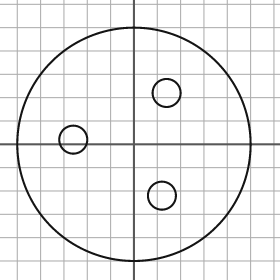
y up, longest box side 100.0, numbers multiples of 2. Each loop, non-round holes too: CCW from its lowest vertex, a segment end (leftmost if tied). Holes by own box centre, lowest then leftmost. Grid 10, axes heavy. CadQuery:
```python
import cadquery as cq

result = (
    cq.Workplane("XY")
    .moveTo(0.0, 0.0)
    .circle(50.0)
    .moveTo(12.0, -22.0)
    .circle(6.0)
    .moveTo(-26.0, 2.0)
    .circle(6.0)
    .moveTo(14.0, 22.0)
    .circle(6.0)
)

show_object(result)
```